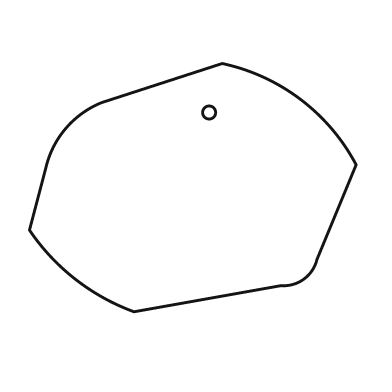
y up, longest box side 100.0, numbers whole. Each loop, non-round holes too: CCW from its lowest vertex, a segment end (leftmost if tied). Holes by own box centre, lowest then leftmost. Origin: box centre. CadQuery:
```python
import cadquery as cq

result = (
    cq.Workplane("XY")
    .moveTo(-18.0, -38.0)
    .lineTo(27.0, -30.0)
    .threePointArc((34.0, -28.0), (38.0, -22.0))
    .lineTo(50.0, 7.0)
    .threePointArc((33.0, 27.0), (9.0, 38.0))
    .lineTo(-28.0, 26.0)
    .threePointArc((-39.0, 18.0), (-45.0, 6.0))
    .lineTo(-50.0, -13.0)
    .threePointArc((-36.0, -28.0), (-18.0, -38.0))
    .close()
    .moveTo(5.0, 23.0)
    .circle(2.0)
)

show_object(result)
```